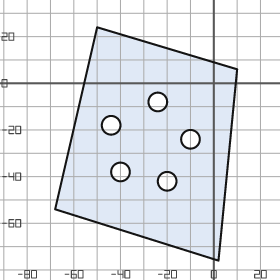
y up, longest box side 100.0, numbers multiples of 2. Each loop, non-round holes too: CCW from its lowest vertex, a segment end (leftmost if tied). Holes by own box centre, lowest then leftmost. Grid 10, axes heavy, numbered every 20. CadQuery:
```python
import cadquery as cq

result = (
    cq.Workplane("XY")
    .moveTo(2.0, -76.0)
    .lineTo(10.0, 6.0)
    .lineTo(-50.0, 24.0)
    .lineTo(-68.0, -54.0)
    .close()
    .moveTo(-20.0, -42.0)
    .circle(4.0)
    .moveTo(-40.0, -38.0)
    .circle(4.0)
    .moveTo(-10.0, -24.0)
    .circle(4.0)
    .moveTo(-44.0, -18.0)
    .circle(4.0)
    .moveTo(-24.0, -8.0)
    .circle(4.0)
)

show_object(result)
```